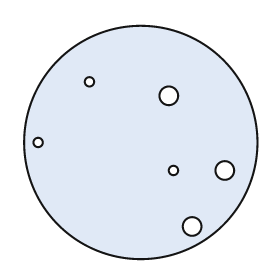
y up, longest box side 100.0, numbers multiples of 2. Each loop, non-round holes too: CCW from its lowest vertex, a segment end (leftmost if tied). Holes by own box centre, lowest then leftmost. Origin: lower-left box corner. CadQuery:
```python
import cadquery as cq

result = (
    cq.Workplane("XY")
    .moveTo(50.0, 50.0)
    .circle(50.0)
    .moveTo(72.0, 14.0)
    .circle(4.0)
    .moveTo(64.0, 38.0)
    .circle(2.0)
    .moveTo(86.0, 38.0)
    .circle(4.0)
    .moveTo(6.0, 50.0)
    .circle(2.0)
    .moveTo(62.0, 70.0)
    .circle(4.0)
    .moveTo(28.0, 76.0)
    .circle(2.0)
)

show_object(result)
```